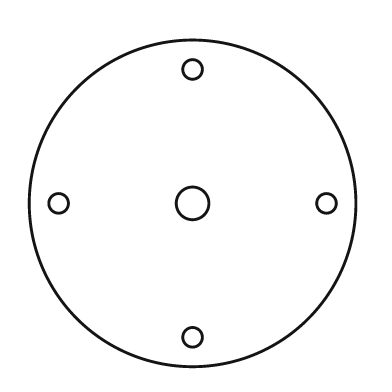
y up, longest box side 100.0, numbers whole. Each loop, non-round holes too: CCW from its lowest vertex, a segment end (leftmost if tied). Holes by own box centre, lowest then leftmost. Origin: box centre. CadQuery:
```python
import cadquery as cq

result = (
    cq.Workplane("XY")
    .moveTo(0.0, 0.0)
    .circle(50.0)
    .moveTo(0.0, -41.0)
    .circle(3.0)
    .moveTo(-41.0, 0.0)
    .circle(3.0)
    .moveTo(0.0, 0.0)
    .circle(5.0)
    .moveTo(41.0, 0.0)
    .circle(3.0)
    .moveTo(0.0, 41.0)
    .circle(3.0)
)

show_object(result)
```